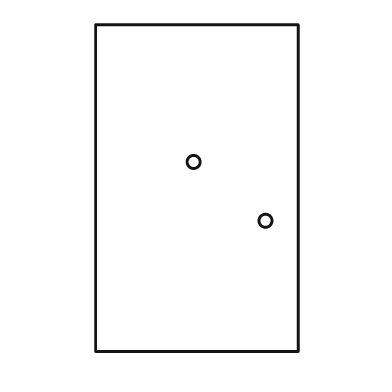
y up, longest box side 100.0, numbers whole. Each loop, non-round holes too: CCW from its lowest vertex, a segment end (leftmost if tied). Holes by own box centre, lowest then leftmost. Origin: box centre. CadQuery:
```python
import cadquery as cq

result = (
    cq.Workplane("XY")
    .moveTo(-31.0, -50.0)
    .lineTo(31.0, -50.0)
    .lineTo(31.0, 50.0)
    .lineTo(-31.0, 50.0)
    .close()
    .moveTo(21.0, -10.0)
    .circle(2.0)
    .moveTo(-1.0, 8.0)
    .circle(2.0)
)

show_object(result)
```